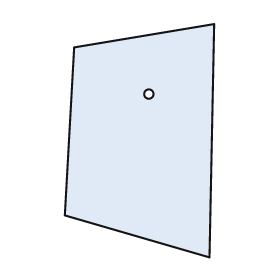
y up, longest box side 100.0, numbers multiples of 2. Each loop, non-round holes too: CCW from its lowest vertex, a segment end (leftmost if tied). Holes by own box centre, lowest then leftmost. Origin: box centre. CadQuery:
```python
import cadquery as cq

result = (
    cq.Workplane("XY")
    .moveTo(30.0, -50.0)
    .lineTo(32.0, 50.0)
    .lineTo(-28.0, 40.0)
    .lineTo(-32.0, -32.0)
    .close()
    .moveTo(4.0, 20.0)
    .circle(2.0)
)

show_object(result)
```